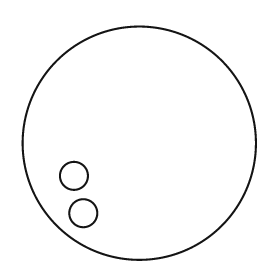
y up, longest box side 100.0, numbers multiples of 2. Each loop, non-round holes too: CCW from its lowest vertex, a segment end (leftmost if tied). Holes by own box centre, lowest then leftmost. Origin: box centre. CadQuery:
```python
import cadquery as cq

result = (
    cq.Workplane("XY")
    .moveTo(0.0, 0.0)
    .circle(50.0)
    .moveTo(-24.0, -30.0)
    .circle(6.0)
    .moveTo(-28.0, -14.0)
    .circle(6.0)
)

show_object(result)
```